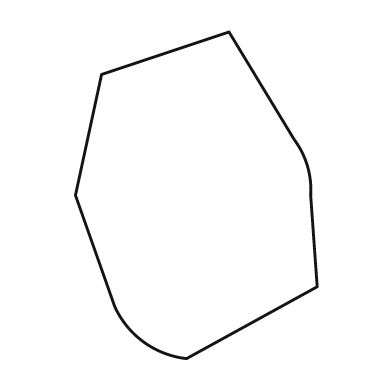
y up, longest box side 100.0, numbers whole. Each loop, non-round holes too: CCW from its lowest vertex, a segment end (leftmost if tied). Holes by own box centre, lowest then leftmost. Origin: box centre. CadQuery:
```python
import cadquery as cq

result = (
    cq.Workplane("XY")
    .moveTo(-3.0, -50.0)
    .lineTo(37.0, -28.0)
    .lineTo(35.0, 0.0)
    .threePointArc((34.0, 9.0), (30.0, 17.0))
    .lineTo(10.0, 50.0)
    .lineTo(-29.0, 37.0)
    .lineTo(-37.0, 0.0)
    .lineTo(-25.0, -34.0)
    .threePointArc((-16.0, -45.0), (-3.0, -50.0))
    .close()
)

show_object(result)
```